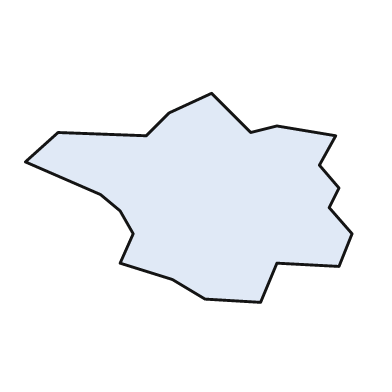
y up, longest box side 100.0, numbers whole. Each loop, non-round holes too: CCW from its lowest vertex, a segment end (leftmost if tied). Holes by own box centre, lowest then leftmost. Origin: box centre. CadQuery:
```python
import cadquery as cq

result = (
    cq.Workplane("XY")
    .moveTo(22.0, -32.0)
    .lineTo(27.0, -20.0)
    .lineTo(46.0, -21.0)
    .lineTo(50.0, -11.0)
    .lineTo(43.0, -3.0)
    .lineTo(46.0, 3.0)
    .lineTo(40.0, 10.0)
    .lineTo(45.0, 19.0)
    .lineTo(27.0, 22.0)
    .lineTo(19.0, 20.0)
    .lineTo(7.0, 32.0)
    .lineTo(-6.0, 26.0)
    .lineTo(-13.0, 19.0)
    .lineTo(-40.0, 20.0)
    .lineTo(-50.0, 11.0)
    .lineTo(-27.0, 1.0)
    .lineTo(-21.0, -4.0)
    .lineTo(-17.0, -11.0)
    .lineTo(-21.0, -20.0)
    .lineTo(-5.0, -25.0)
    .lineTo(5.0, -31.0)
    .close()
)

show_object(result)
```